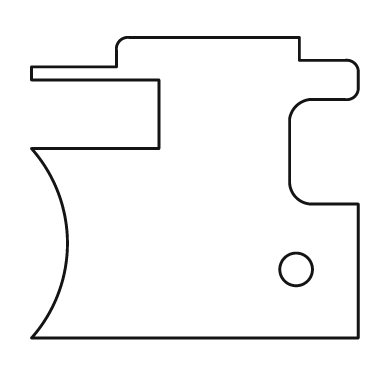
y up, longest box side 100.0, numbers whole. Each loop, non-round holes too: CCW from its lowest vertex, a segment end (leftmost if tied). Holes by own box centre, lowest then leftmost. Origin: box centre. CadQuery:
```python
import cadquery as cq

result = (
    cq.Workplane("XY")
    .moveTo(-50.0, -46.0)
    .lineTo(50.0, -46.0)
    .lineTo(50.0, -5.0)
    .lineTo(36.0, -5.0)
    .threePointArc((31.0, -3.0), (29.0, 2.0))
    .lineTo(29.0, 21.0)
    .threePointArc((31.0, 25.0), (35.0, 27.0))
    .lineTo(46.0, 27.0)
    .threePointArc((49.0, 28.0), (50.0, 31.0))
    .lineTo(50.0, 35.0)
    .threePointArc((49.0, 38.0), (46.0, 39.0))
    .lineTo(32.0, 39.0)
    .lineTo(32.0, 46.0)
    .lineTo(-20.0, 46.0)
    .threePointArc((-23.0, 45.0), (-24.0, 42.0))
    .lineTo(-24.0, 37.0)
    .lineTo(-50.0, 37.0)
    .lineTo(-50.0, 33.0)
    .lineTo(-11.0, 33.0)
    .lineTo(-11.0, 12.0)
    .lineTo(-50.0, 12.0)
    .threePointArc((-39.0, -17.0), (-50.0, -46.0))
    .close()
    .moveTo(31.0, -25.0)
    .circle(5.0)
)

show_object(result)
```